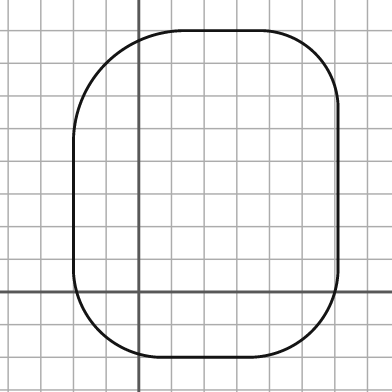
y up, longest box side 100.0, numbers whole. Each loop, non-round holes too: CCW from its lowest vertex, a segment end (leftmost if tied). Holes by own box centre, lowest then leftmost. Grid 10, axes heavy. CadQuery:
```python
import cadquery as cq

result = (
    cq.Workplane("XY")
    .moveTo(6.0, -20.0)
    .lineTo(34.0, -20.0)
    .threePointArc((53.0, -12.0), (61.0, 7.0))
    .lineTo(61.0, 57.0)
    .threePointArc((54.0, 73.0), (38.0, 80.0))
    .lineTo(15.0, 80.0)
    .threePointArc((-10.0, 70.0), (-20.0, 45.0))
    .lineTo(-20.0, 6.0)
    .threePointArc((-12.0, -12.0), (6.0, -20.0))
    .close()
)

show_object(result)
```